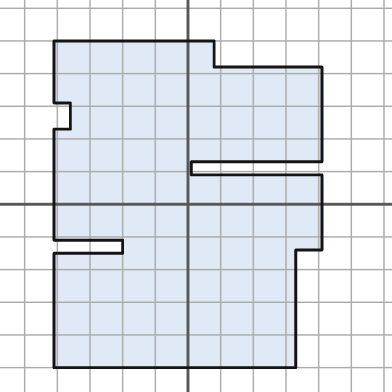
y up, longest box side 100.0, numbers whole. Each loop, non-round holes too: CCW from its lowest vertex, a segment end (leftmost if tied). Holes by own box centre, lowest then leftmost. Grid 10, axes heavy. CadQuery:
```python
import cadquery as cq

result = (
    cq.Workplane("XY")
    .moveTo(-41.0, -50.0)
    .lineTo(33.0, -50.0)
    .lineTo(33.0, -14.0)
    .lineTo(41.0, -14.0)
    .lineTo(41.0, 9.0)
    .lineTo(1.0, 9.0)
    .lineTo(1.0, 13.0)
    .lineTo(41.0, 13.0)
    .lineTo(41.0, 42.0)
    .lineTo(8.0, 42.0)
    .lineTo(8.0, 50.0)
    .lineTo(-41.0, 50.0)
    .lineTo(-41.0, 31.0)
    .lineTo(-36.0, 31.0)
    .lineTo(-36.0, 23.0)
    .lineTo(-41.0, 23.0)
    .lineTo(-41.0, -11.0)
    .lineTo(-20.0, -11.0)
    .lineTo(-20.0, -15.0)
    .lineTo(-41.0, -15.0)
    .close()
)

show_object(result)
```